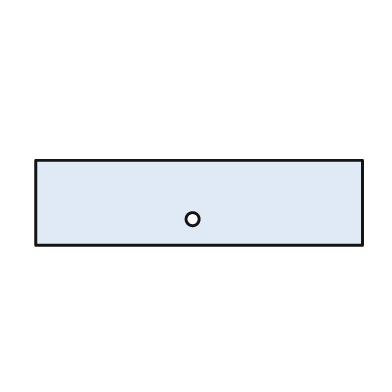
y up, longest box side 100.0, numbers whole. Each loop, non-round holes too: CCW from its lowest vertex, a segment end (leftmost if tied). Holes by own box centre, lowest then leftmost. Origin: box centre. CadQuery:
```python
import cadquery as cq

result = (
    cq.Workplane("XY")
    .moveTo(-50.0, -13.0)
    .lineTo(50.0, -13.0)
    .lineTo(50.0, 13.0)
    .lineTo(-50.0, 13.0)
    .close()
    .moveTo(-2.0, -5.0)
    .circle(2.0)
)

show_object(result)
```